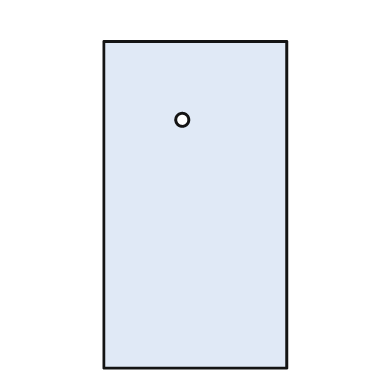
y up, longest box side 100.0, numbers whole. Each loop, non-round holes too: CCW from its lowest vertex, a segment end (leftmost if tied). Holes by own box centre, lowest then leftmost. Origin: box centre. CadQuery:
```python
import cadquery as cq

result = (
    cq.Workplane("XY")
    .moveTo(-28.0, -50.0)
    .lineTo(28.0, -50.0)
    .lineTo(28.0, 50.0)
    .lineTo(-28.0, 50.0)
    .close()
    .moveTo(-4.0, 26.0)
    .circle(2.0)
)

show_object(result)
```